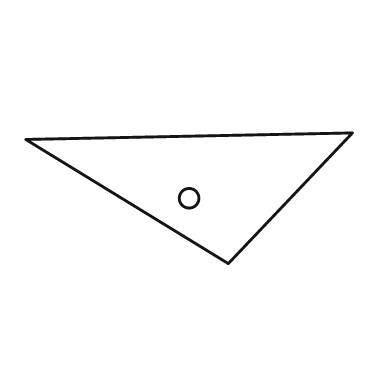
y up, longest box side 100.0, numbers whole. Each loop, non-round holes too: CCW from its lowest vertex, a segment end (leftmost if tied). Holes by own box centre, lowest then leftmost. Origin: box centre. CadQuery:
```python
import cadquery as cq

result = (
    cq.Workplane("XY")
    .moveTo(12.0, -20.0)
    .lineTo(50.0, 20.0)
    .lineTo(-50.0, 18.0)
    .close()
    .moveTo(0.0, 0.0)
    .circle(3.0)
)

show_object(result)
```